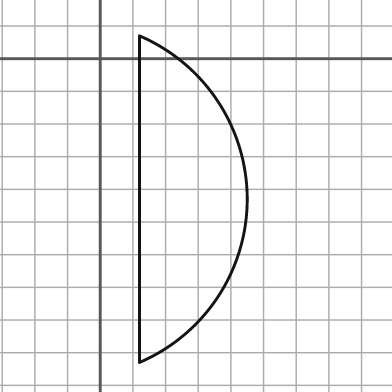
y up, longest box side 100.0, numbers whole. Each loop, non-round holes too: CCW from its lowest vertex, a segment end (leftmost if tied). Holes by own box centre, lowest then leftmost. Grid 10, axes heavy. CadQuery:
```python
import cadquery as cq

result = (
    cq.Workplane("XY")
    .moveTo(12.0, -93.0)
    .threePointArc((45.0, -43.0), (12.0, 7.0))
    .close()
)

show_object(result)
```